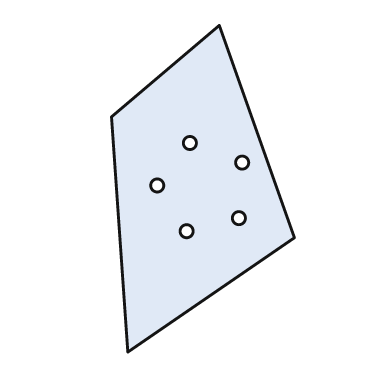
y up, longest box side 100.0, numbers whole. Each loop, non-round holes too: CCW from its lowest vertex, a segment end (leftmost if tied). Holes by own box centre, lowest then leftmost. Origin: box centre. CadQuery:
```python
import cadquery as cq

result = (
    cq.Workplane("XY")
    .moveTo(-23.0, -50.0)
    .lineTo(28.0, -15.0)
    .lineTo(5.0, 50.0)
    .lineTo(-28.0, 22.0)
    .close()
    .moveTo(-5.0, -13.0)
    .circle(2.0)
    .moveTo(11.0, -9.0)
    .circle(2.0)
    .moveTo(-14.0, 1.0)
    .circle(2.0)
    .moveTo(12.0, 8.0)
    .circle(2.0)
    .moveTo(-4.0, 14.0)
    .circle(2.0)
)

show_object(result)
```